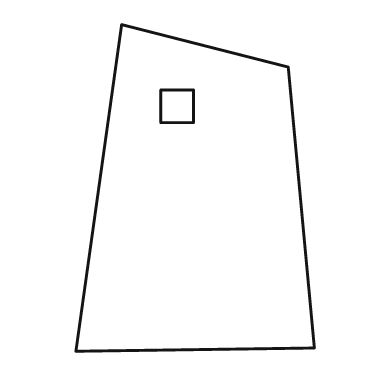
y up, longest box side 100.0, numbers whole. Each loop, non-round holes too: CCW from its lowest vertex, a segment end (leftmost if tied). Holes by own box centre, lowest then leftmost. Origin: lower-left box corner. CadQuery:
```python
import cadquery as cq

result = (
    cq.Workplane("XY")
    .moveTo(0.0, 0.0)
    .lineTo(73.0, 1.0)
    .lineTo(65.0, 87.0)
    .lineTo(14.0, 100.0)
    .close()
    .moveTo(26.0, 70.0)
    .lineTo(36.0, 70.0)
    .lineTo(36.0, 80.0)
    .lineTo(26.0, 80.0)
    .close()
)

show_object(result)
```